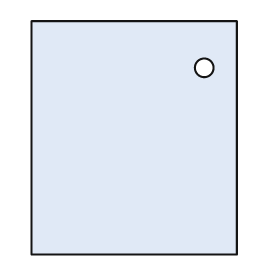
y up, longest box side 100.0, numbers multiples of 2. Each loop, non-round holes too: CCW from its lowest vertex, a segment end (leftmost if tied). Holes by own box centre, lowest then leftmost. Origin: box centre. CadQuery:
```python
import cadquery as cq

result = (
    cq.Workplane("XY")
    .moveTo(-44.0, -50.0)
    .lineTo(44.0, -50.0)
    .lineTo(44.0, 50.0)
    .lineTo(-44.0, 50.0)
    .close()
    .moveTo(30.0, 30.0)
    .circle(4.0)
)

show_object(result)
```